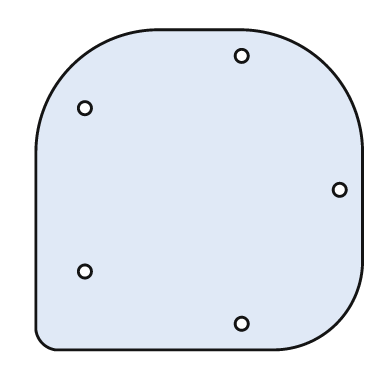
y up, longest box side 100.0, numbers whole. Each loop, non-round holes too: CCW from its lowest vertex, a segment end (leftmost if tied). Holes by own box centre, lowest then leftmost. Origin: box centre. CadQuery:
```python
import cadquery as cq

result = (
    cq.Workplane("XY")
    .moveTo(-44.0, -49.0)
    .lineTo(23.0, -49.0)
    .threePointArc((42.0, -41.0), (50.0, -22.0))
    .lineTo(50.0, 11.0)
    .threePointArc((39.0, 38.0), (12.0, 49.0))
    .lineTo(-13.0, 49.0)
    .threePointArc((-39.0, 38.0), (-50.0, 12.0))
    .lineTo(-50.0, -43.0)
    .threePointArc((-48.0, -47.0), (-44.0, -49.0))
    .close()
    .moveTo(13.0, -41.0)
    .circle(2.0)
    .moveTo(-35.0, -25.0)
    .circle(2.0)
    .moveTo(43.0, 0.0)
    .circle(2.0)
    .moveTo(-35.0, 25.0)
    .circle(2.0)
    .moveTo(13.0, 41.0)
    .circle(2.0)
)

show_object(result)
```